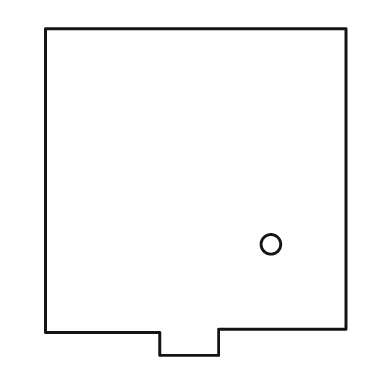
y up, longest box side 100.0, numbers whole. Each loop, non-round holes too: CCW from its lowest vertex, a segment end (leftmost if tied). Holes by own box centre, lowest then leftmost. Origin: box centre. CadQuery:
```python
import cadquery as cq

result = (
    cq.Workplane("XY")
    .moveTo(-11.0, -50.0)
    .lineTo(7.0, -50.0)
    .lineTo(7.0, -42.0)
    .lineTo(46.0, -42.0)
    .lineTo(46.0, 50.0)
    .lineTo(-46.0, 50.0)
    .lineTo(-46.0, -43.0)
    .lineTo(-11.0, -43.0)
    .close()
    .moveTo(23.0, -16.0)
    .circle(3.0)
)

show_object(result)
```